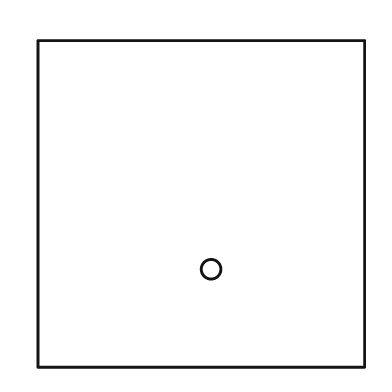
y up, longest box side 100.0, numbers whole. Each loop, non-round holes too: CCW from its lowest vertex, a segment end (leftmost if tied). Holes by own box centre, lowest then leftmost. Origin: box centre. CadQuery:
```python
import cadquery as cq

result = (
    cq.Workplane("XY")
    .moveTo(-50.0, -50.0)
    .lineTo(50.0, -50.0)
    .lineTo(50.0, 50.0)
    .lineTo(-50.0, 50.0)
    .close()
    .moveTo(3.0, -20.0)
    .circle(3.0)
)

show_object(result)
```